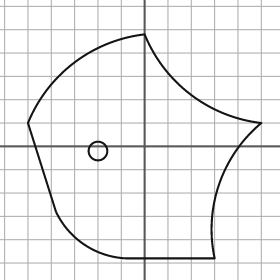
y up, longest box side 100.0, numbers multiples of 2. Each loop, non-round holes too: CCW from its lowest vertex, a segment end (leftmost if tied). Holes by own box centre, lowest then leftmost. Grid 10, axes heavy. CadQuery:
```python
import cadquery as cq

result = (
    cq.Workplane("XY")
    .moveTo(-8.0, -48.0)
    .lineTo(30.0, -48.0)
    .threePointArc((32.0, -16.0), (50.0, 10.0))
    .threePointArc((20.0, 22.0), (0.0, 48.0))
    .threePointArc((-30.0, 36.0), (-50.0, 10.0))
    .lineTo(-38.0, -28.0)
    .threePointArc((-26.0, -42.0), (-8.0, -48.0))
    .close()
    .moveTo(-20.0, -2.0)
    .circle(4.0)
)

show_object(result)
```